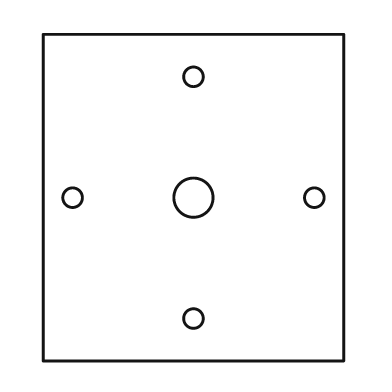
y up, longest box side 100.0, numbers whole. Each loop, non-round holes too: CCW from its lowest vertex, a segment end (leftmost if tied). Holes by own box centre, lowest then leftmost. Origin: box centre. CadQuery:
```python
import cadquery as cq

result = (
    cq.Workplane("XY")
    .moveTo(-46.0, -50.0)
    .lineTo(46.0, -50.0)
    .lineTo(46.0, 50.0)
    .lineTo(-46.0, 50.0)
    .close()
    .moveTo(0.0, -37.0)
    .circle(3.0)
    .moveTo(-37.0, 0.0)
    .circle(3.0)
    .moveTo(0.0, 0.0)
    .circle(6.0)
    .moveTo(37.0, 0.0)
    .circle(3.0)
    .moveTo(0.0, 37.0)
    .circle(3.0)
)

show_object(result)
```